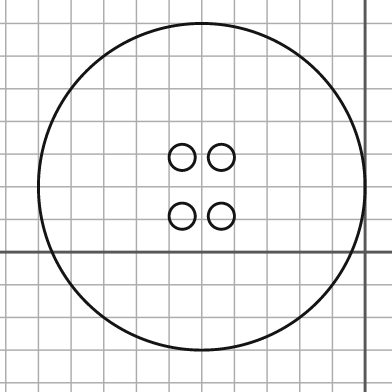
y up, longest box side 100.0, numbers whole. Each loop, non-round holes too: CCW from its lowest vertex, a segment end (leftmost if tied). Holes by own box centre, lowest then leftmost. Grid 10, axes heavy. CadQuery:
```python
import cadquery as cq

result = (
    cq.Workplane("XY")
    .moveTo(-50.0, 20.0)
    .circle(50.0)
    .moveTo(-56.0, 11.0)
    .circle(4.0)
    .moveTo(-44.0, 11.0)
    .circle(4.0)
    .moveTo(-56.0, 29.0)
    .circle(4.0)
    .moveTo(-44.0, 29.0)
    .circle(4.0)
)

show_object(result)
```